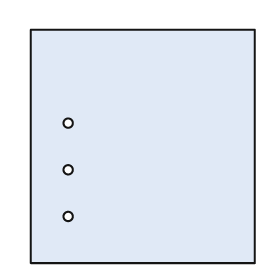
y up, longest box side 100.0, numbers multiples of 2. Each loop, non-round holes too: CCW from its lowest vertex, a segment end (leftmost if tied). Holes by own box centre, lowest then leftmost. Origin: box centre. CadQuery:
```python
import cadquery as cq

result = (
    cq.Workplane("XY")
    .moveTo(-48.0, -50.0)
    .lineTo(48.0, -50.0)
    .lineTo(48.0, 50.0)
    .lineTo(-48.0, 50.0)
    .close()
    .moveTo(-32.0, -30.0)
    .circle(2.0)
    .moveTo(-32.0, -10.0)
    .circle(2.0)
    .moveTo(-32.0, 10.0)
    .circle(2.0)
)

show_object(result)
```